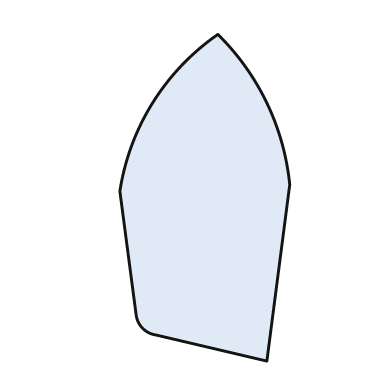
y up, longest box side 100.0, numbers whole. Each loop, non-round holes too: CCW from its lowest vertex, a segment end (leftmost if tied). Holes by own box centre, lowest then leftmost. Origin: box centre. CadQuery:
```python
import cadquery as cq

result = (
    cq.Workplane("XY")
    .moveTo(19.0, -50.0)
    .lineTo(26.0, 4.0)
    .threePointArc((19.0, 29.0), (4.0, 50.0))
    .threePointArc((-16.0, 29.0), (-26.0, 2.0))
    .lineTo(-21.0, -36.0)
    .threePointArc((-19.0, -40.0), (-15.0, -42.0))
    .close()
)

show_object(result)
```